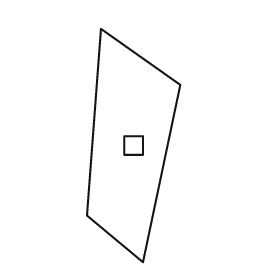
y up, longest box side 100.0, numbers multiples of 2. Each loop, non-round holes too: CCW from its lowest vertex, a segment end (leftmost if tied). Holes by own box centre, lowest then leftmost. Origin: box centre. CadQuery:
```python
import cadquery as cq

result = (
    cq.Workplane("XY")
    .moveTo(4.0, -50.0)
    .lineTo(20.0, 26.0)
    .lineTo(-14.0, 50.0)
    .lineTo(-20.0, -30.0)
    .close()
    .moveTo(-4.0, -4.0)
    .lineTo(4.0, -4.0)
    .lineTo(4.0, 4.0)
    .lineTo(-4.0, 4.0)
    .close()
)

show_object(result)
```